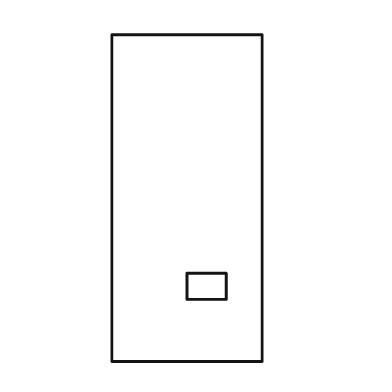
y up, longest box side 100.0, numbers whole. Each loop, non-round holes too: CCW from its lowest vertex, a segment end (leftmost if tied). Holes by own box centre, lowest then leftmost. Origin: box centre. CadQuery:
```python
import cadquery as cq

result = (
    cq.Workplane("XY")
    .moveTo(-23.0, -50.0)
    .lineTo(23.0, -50.0)
    .lineTo(23.0, 50.0)
    .lineTo(-23.0, 50.0)
    .close()
    .moveTo(0.0, -31.0)
    .lineTo(12.0, -31.0)
    .lineTo(12.0, -23.0)
    .lineTo(0.0, -23.0)
    .close()
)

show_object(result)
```